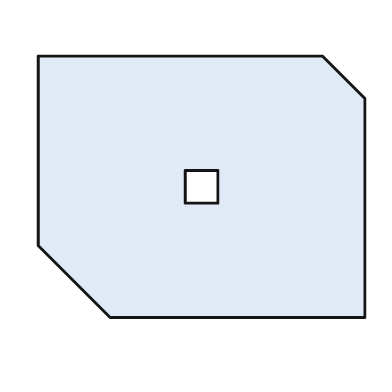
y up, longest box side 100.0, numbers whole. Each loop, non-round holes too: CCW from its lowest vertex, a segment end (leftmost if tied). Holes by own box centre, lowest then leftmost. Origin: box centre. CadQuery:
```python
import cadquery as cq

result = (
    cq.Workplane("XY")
    .moveTo(-28.0, -40.0)
    .lineTo(50.0, -40.0)
    .lineTo(50.0, 27.0)
    .lineTo(37.0, 40.0)
    .lineTo(-50.0, 40.0)
    .lineTo(-50.0, -18.0)
    .close()
    .moveTo(-5.0, -5.0)
    .lineTo(5.0, -5.0)
    .lineTo(5.0, 5.0)
    .lineTo(-5.0, 5.0)
    .close()
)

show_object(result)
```